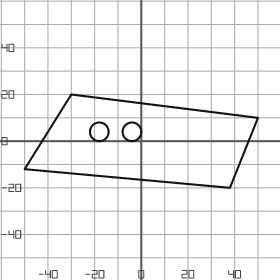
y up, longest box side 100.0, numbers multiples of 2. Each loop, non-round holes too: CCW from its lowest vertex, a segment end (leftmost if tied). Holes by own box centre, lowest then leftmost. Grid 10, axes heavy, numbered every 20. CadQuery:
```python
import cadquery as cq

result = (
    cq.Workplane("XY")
    .moveTo(38.0, -20.0)
    .lineTo(50.0, 10.0)
    .lineTo(-30.0, 20.0)
    .lineTo(-50.0, -12.0)
    .close()
    .moveTo(-18.0, 4.0)
    .circle(4.0)
    .moveTo(-4.0, 4.0)
    .circle(4.0)
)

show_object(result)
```